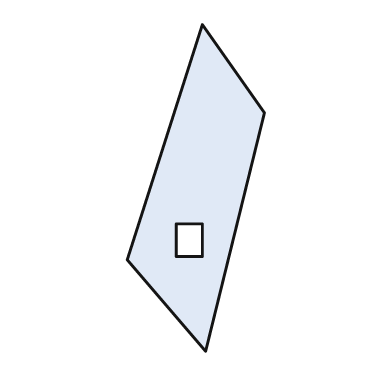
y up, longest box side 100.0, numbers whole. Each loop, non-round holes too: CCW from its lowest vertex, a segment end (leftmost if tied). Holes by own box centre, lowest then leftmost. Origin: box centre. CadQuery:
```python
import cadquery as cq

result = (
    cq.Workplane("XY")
    .moveTo(3.0, -50.0)
    .lineTo(21.0, 23.0)
    .lineTo(2.0, 50.0)
    .lineTo(-21.0, -22.0)
    .close()
    .moveTo(-6.0, -21.0)
    .lineTo(2.0, -21.0)
    .lineTo(2.0, -11.0)
    .lineTo(-6.0, -11.0)
    .close()
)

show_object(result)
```